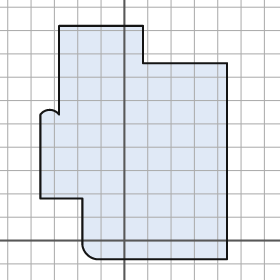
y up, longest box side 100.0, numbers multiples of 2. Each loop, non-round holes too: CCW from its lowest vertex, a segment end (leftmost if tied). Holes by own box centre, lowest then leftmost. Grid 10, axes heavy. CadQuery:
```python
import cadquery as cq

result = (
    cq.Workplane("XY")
    .moveTo(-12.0, -8.0)
    .lineTo(44.0, -8.0)
    .lineTo(44.0, 76.0)
    .lineTo(8.0, 76.0)
    .lineTo(8.0, 92.0)
    .lineTo(-28.0, 92.0)
    .lineTo(-28.0, 54.0)
    .threePointArc((-32.0, 56.0), (-36.0, 54.0))
    .lineTo(-36.0, 18.0)
    .lineTo(-18.0, 18.0)
    .lineTo(-18.0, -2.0)
    .threePointArc((-16.0, -6.0), (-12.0, -8.0))
    .close()
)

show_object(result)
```